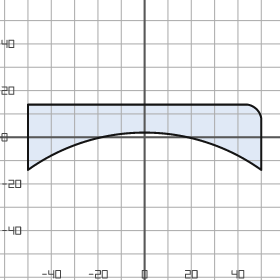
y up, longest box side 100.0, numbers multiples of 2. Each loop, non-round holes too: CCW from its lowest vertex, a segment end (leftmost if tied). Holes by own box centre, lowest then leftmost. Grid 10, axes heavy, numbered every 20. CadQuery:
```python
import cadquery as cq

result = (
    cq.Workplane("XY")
    .moveTo(-50.0, -14.0)
    .threePointArc((0.0, 2.0), (50.0, -14.0))
    .lineTo(50.0, 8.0)
    .threePointArc((48.0, 12.0), (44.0, 14.0))
    .lineTo(-50.0, 14.0)
    .close()
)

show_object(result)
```